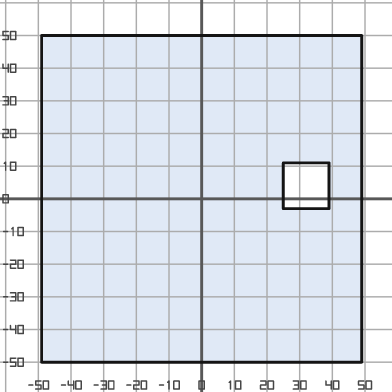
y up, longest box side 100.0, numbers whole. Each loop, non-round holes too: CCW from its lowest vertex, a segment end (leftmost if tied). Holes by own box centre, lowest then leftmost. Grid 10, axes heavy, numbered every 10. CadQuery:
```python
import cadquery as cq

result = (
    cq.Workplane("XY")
    .moveTo(-49.0, -50.0)
    .lineTo(49.0, -50.0)
    .lineTo(49.0, 50.0)
    .lineTo(-49.0, 50.0)
    .close()
    .moveTo(25.0, -3.0)
    .lineTo(39.0, -3.0)
    .lineTo(39.0, 11.0)
    .lineTo(25.0, 11.0)
    .close()
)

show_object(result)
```